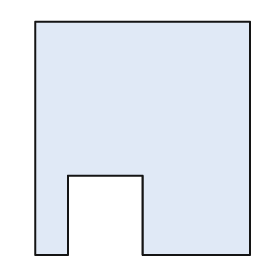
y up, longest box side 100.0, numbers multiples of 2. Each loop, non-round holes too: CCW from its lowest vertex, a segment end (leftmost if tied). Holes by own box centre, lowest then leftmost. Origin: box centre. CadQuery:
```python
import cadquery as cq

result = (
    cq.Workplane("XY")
    .moveTo(-46.0, -50.0)
    .lineTo(-32.0, -50.0)
    .lineTo(-32.0, -16.0)
    .lineTo(0.0, -16.0)
    .lineTo(0.0, -50.0)
    .lineTo(46.0, -50.0)
    .lineTo(46.0, 50.0)
    .lineTo(-46.0, 50.0)
    .close()
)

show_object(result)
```